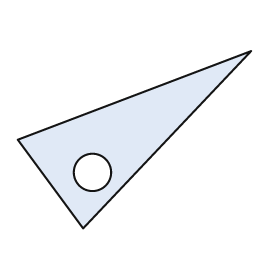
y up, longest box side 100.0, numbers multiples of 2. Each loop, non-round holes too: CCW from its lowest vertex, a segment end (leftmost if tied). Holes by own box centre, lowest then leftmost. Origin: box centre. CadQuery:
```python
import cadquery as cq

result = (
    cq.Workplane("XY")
    .moveTo(-22.0, -38.0)
    .lineTo(50.0, 38.0)
    .lineTo(-50.0, 0.0)
    .close()
    .moveTo(-18.0, -14.0)
    .circle(8.0)
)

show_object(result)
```